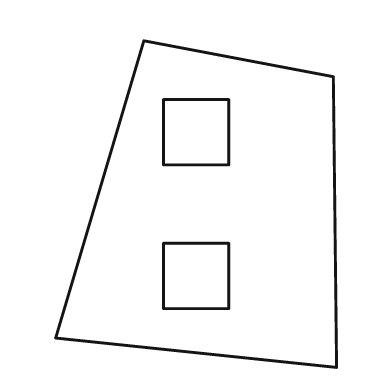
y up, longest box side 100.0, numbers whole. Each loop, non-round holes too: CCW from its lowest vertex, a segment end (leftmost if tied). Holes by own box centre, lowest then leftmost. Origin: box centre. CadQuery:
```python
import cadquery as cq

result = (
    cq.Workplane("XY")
    .moveTo(43.0, -50.0)
    .lineTo(42.0, 39.0)
    .lineTo(-16.0, 50.0)
    .lineTo(-43.0, -41.0)
    .close()
    .moveTo(-10.0, -32.0)
    .lineTo(10.0, -32.0)
    .lineTo(10.0, -12.0)
    .lineTo(-10.0, -12.0)
    .close()
    .moveTo(-10.0, 12.0)
    .lineTo(10.0, 12.0)
    .lineTo(10.0, 32.0)
    .lineTo(-10.0, 32.0)
    .close()
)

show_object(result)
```